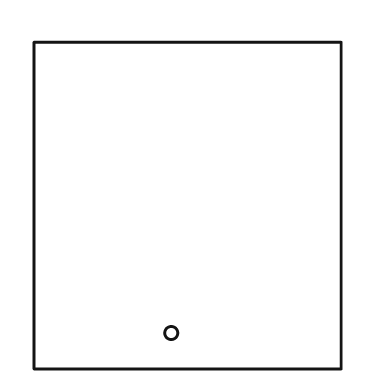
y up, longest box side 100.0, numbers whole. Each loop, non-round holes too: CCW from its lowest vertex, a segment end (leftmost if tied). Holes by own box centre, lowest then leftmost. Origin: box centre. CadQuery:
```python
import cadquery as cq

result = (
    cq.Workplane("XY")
    .moveTo(-47.0, -50.0)
    .lineTo(47.0, -50.0)
    .lineTo(47.0, 50.0)
    .lineTo(-47.0, 50.0)
    .close()
    .moveTo(-5.0, -39.0)
    .circle(2.0)
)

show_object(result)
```